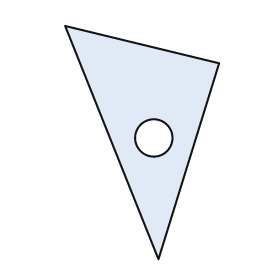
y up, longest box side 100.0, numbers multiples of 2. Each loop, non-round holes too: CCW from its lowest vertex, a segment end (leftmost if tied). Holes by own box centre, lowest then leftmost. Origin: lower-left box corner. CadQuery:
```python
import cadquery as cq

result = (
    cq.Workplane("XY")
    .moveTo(40.0, 0.0)
    .lineTo(66.0, 84.0)
    .lineTo(0.0, 100.0)
    .close()
    .moveTo(38.0, 52.0)
    .circle(8.0)
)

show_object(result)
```